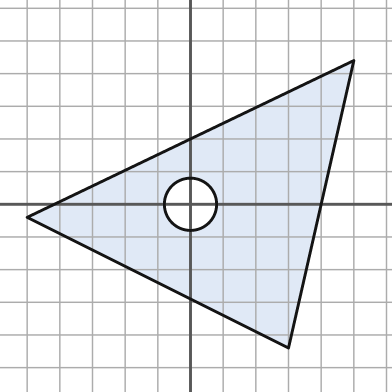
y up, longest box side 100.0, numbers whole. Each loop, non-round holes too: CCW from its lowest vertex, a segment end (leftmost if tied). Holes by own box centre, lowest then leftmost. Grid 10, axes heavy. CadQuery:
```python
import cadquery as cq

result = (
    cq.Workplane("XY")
    .moveTo(30.0, -44.0)
    .lineTo(50.0, 44.0)
    .lineTo(-50.0, -4.0)
    .close()
    .moveTo(0.0, 0.0)
    .circle(8.0)
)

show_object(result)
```